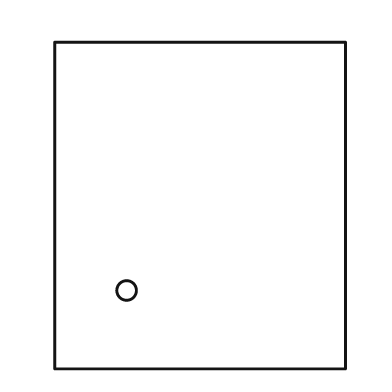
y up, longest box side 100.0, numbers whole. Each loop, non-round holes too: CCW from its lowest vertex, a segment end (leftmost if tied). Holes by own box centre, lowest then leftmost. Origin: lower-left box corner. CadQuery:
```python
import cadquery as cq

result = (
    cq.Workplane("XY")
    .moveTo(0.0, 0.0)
    .lineTo(89.0, 0.0)
    .lineTo(89.0, 100.0)
    .lineTo(0.0, 100.0)
    .close()
    .moveTo(22.0, 24.0)
    .circle(3.0)
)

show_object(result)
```